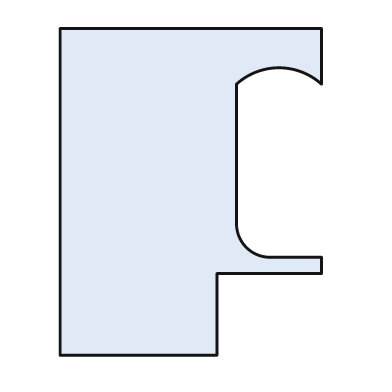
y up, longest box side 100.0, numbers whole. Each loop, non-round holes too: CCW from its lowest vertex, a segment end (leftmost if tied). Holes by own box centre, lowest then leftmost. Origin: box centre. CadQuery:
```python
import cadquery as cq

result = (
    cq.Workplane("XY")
    .moveTo(-40.0, -50.0)
    .lineTo(8.0, -50.0)
    .lineTo(8.0, -25.0)
    .lineTo(40.0, -25.0)
    .lineTo(40.0, -20.0)
    .lineTo(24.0, -20.0)
    .threePointArc((17.0, -17.0), (14.0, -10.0))
    .lineTo(14.0, 33.0)
    .threePointArc((27.0, 38.0), (40.0, 33.0))
    .lineTo(40.0, 50.0)
    .lineTo(-40.0, 50.0)
    .close()
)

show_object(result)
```